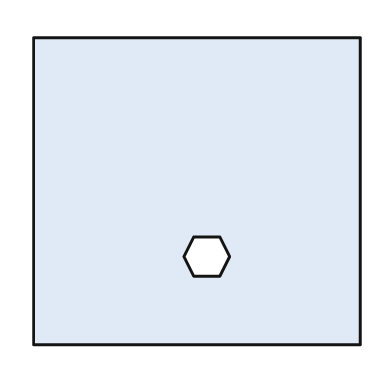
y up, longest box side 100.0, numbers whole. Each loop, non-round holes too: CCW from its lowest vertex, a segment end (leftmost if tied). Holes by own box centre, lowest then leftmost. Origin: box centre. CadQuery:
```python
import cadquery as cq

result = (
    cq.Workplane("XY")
    .moveTo(-50.0, -47.0)
    .lineTo(50.0, -47.0)
    .lineTo(50.0, 47.0)
    .lineTo(-50.0, 47.0)
    .close()
    .moveTo(-1.0, -26.0)
    .lineTo(7.0, -26.0)
    .lineTo(10.0, -20.0)
    .lineTo(7.0, -14.0)
    .lineTo(-1.0, -14.0)
    .lineTo(-4.0, -20.0)
    .close()
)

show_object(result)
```